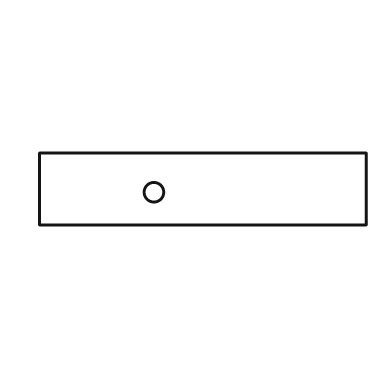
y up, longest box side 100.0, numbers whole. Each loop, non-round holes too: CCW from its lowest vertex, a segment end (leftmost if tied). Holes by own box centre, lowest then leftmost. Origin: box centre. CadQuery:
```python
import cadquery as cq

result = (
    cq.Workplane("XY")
    .moveTo(-50.0, -11.0)
    .lineTo(50.0, -11.0)
    .lineTo(50.0, 11.0)
    .lineTo(-50.0, 11.0)
    .close()
    .moveTo(-15.0, -1.0)
    .circle(3.0)
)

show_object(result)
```